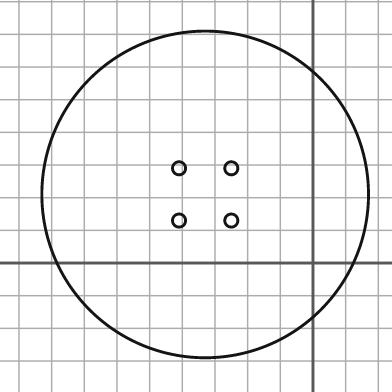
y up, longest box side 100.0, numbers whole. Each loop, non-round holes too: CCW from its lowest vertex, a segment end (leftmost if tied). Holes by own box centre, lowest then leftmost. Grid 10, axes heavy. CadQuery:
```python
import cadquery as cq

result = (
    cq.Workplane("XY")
    .moveTo(-33.0, 21.0)
    .circle(50.0)
    .moveTo(-41.0, 13.0)
    .circle(2.0)
    .moveTo(-25.0, 13.0)
    .circle(2.0)
    .moveTo(-41.0, 29.0)
    .circle(2.0)
    .moveTo(-25.0, 29.0)
    .circle(2.0)
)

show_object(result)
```